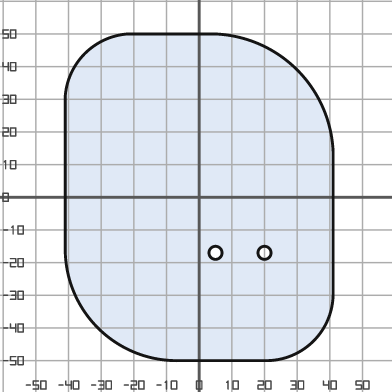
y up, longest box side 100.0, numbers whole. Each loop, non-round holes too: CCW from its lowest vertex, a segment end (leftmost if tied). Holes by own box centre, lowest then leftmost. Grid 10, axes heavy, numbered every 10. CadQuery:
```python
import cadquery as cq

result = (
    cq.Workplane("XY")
    .moveTo(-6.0, -50.0)
    .lineTo(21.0, -50.0)
    .threePointArc((35.0, -44.0), (41.0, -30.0))
    .lineTo(41.0, 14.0)
    .threePointArc((30.0, 39.0), (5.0, 50.0))
    .lineTo(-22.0, 50.0)
    .threePointArc((-35.0, 44.0), (-41.0, 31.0))
    .lineTo(-41.0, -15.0)
    .threePointArc((-31.0, -40.0), (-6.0, -50.0))
    .close()
    .moveTo(5.0, -17.0)
    .circle(2.0)
    .moveTo(20.0, -17.0)
    .circle(2.0)
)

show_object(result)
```